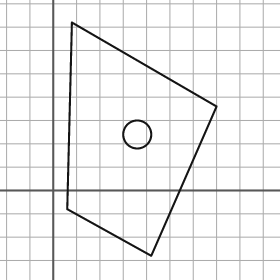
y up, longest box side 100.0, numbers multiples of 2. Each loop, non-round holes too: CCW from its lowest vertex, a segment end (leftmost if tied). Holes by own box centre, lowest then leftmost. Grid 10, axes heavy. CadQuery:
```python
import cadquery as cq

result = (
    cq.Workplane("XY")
    .moveTo(42.0, -28.0)
    .lineTo(70.0, 36.0)
    .lineTo(8.0, 72.0)
    .lineTo(6.0, -8.0)
    .close()
    .moveTo(36.0, 24.0)
    .circle(6.0)
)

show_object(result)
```